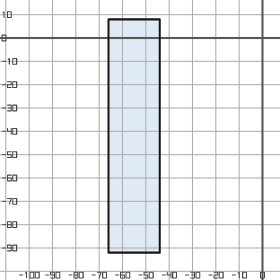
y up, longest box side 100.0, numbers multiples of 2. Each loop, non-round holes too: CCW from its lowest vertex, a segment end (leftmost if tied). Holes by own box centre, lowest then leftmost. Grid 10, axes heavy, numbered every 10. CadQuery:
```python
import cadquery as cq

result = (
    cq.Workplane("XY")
    .moveTo(-66.0, -92.0)
    .lineTo(-44.0, -92.0)
    .lineTo(-44.0, 8.0)
    .lineTo(-66.0, 8.0)
    .close()
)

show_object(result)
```